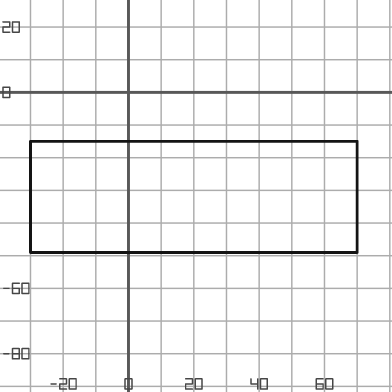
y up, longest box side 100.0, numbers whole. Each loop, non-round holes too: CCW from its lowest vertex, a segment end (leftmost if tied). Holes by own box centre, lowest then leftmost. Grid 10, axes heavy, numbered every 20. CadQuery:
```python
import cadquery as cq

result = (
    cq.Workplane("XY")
    .moveTo(-30.0, -49.0)
    .lineTo(70.0, -49.0)
    .lineTo(70.0, -15.0)
    .lineTo(-30.0, -15.0)
    .close()
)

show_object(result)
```